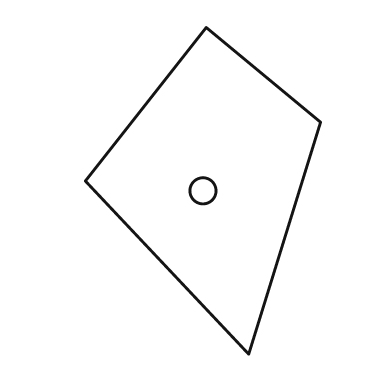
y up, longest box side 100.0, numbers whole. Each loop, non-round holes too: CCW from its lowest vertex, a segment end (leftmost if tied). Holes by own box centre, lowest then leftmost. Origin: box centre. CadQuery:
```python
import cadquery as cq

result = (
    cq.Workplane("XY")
    .moveTo(14.0, -50.0)
    .lineTo(36.0, 21.0)
    .lineTo(1.0, 50.0)
    .lineTo(-36.0, 3.0)
    .close()
    .moveTo(0.0, 0.0)
    .circle(4.0)
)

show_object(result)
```